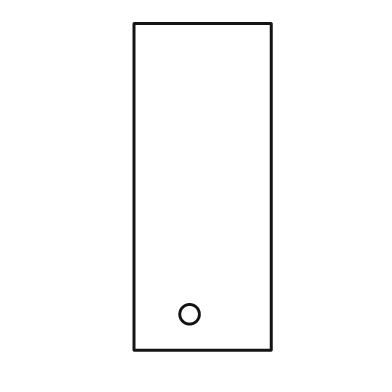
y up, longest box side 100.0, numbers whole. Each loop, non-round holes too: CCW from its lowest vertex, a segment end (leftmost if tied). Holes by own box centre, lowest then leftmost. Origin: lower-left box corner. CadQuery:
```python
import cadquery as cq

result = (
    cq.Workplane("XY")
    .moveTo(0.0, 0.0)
    .lineTo(42.0, 0.0)
    .lineTo(42.0, 100.0)
    .lineTo(0.0, 100.0)
    .close()
    .moveTo(17.0, 11.0)
    .circle(3.0)
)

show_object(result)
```